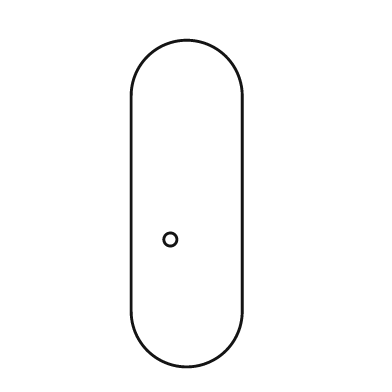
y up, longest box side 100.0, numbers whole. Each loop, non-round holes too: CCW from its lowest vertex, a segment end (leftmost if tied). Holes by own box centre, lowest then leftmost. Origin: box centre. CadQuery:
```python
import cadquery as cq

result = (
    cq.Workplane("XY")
    .moveTo(-17.0, -33.0)
    .threePointArc((0.0, -50.0), (17.0, -33.0))
    .lineTo(17.0, 33.0)
    .threePointArc((0.0, 50.0), (-17.0, 33.0))
    .close()
    .moveTo(-5.0, -11.0)
    .circle(2.0)
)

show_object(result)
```